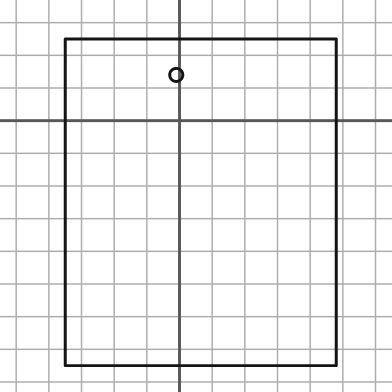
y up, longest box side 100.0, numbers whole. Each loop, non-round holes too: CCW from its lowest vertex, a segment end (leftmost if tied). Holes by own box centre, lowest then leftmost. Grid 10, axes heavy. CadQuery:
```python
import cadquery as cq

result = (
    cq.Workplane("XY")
    .moveTo(-35.0, -75.0)
    .lineTo(48.0, -75.0)
    .lineTo(48.0, 25.0)
    .lineTo(-35.0, 25.0)
    .close()
    .moveTo(-1.0, 14.0)
    .circle(2.0)
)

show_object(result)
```